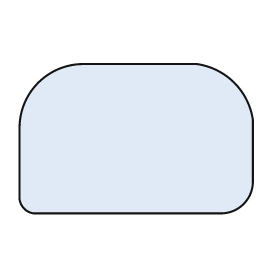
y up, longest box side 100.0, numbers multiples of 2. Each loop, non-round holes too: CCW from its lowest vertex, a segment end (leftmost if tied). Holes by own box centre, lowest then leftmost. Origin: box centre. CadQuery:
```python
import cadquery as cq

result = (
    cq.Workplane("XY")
    .moveTo(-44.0, -32.0)
    .lineTo(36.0, -32.0)
    .threePointArc((46.0, -28.0), (50.0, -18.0))
    .lineTo(50.0, 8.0)
    .threePointArc((42.0, 24.0), (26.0, 32.0))
    .lineTo(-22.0, 32.0)
    .threePointArc((-42.0, 24.0), (-50.0, 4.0))
    .lineTo(-50.0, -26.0)
    .threePointArc((-48.0, -30.0), (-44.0, -32.0))
    .close()
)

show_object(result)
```